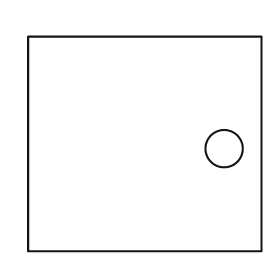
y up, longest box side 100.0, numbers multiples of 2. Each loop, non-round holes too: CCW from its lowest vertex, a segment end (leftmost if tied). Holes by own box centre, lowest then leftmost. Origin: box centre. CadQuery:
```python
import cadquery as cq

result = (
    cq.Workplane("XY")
    .moveTo(-50.0, -46.0)
    .lineTo(50.0, -46.0)
    .lineTo(50.0, 46.0)
    .lineTo(-50.0, 46.0)
    .close()
    .moveTo(34.0, -2.0)
    .circle(8.0)
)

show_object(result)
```